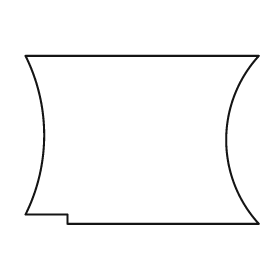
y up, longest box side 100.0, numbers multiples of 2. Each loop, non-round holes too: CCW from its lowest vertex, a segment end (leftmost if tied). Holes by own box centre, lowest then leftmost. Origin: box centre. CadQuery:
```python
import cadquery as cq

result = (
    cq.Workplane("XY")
    .moveTo(-32.0, -36.0)
    .lineTo(50.0, -36.0)
    .threePointArc((36.0, 0.0), (50.0, 36.0))
    .lineTo(-50.0, 36.0)
    .threePointArc((-42.0, 2.0), (-50.0, -32.0))
    .lineTo(-32.0, -32.0)
    .close()
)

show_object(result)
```